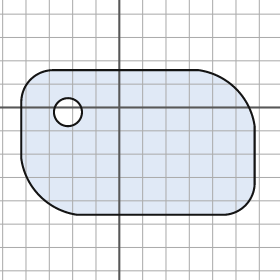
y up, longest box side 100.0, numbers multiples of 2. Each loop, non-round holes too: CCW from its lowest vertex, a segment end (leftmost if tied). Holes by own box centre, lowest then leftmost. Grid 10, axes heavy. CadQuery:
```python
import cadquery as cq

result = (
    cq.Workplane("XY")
    .moveTo(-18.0, -46.0)
    .lineTo(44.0, -46.0)
    .threePointArc((54.0, -42.0), (58.0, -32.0))
    .lineTo(58.0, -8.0)
    .threePointArc((50.0, 8.0), (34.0, 16.0))
    .lineTo(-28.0, 16.0)
    .threePointArc((-38.0, 12.0), (-42.0, 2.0))
    .lineTo(-42.0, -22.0)
    .threePointArc((-34.0, -38.0), (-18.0, -46.0))
    .close()
    .moveTo(-22.0, -2.0)
    .circle(6.0)
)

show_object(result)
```